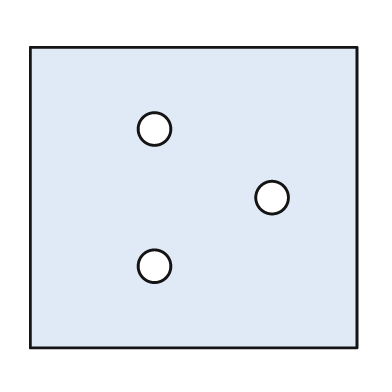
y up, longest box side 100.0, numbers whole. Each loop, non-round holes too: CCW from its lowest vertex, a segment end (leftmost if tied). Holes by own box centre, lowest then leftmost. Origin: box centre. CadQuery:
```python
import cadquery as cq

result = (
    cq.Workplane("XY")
    .moveTo(-50.0, -46.0)
    .lineTo(50.0, -46.0)
    .lineTo(50.0, 46.0)
    .lineTo(-50.0, 46.0)
    .close()
    .moveTo(-12.0, -21.0)
    .circle(5.0)
    .moveTo(24.0, 0.0)
    .circle(5.0)
    .moveTo(-12.0, 21.0)
    .circle(5.0)
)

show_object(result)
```